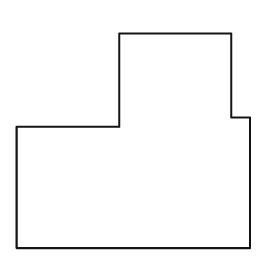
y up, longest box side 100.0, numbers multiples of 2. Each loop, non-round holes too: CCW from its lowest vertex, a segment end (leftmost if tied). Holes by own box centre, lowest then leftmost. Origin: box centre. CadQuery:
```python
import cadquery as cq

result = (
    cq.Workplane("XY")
    .moveTo(-50.0, -46.0)
    .lineTo(50.0, -46.0)
    .lineTo(50.0, 10.0)
    .lineTo(42.0, 10.0)
    .lineTo(42.0, 46.0)
    .lineTo(-6.0, 46.0)
    .lineTo(-6.0, 6.0)
    .lineTo(-50.0, 6.0)
    .close()
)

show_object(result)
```